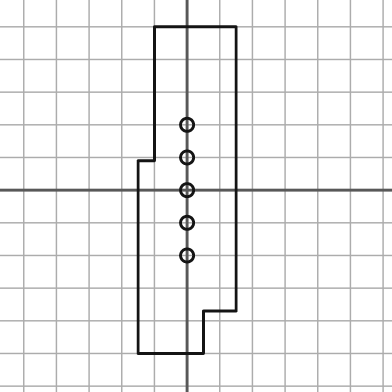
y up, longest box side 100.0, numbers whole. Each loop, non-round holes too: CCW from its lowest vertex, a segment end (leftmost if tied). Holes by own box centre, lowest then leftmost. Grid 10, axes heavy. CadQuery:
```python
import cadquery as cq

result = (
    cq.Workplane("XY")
    .moveTo(-15.0, -50.0)
    .lineTo(5.0, -50.0)
    .lineTo(5.0, -37.0)
    .lineTo(15.0, -37.0)
    .lineTo(15.0, 50.0)
    .lineTo(-10.0, 50.0)
    .lineTo(-10.0, 9.0)
    .lineTo(-15.0, 9.0)
    .close()
    .moveTo(0.0, -20.0)
    .circle(2.0)
    .moveTo(0.0, -10.0)
    .circle(2.0)
    .moveTo(0.0, 0.0)
    .circle(2.0)
    .moveTo(0.0, 10.0)
    .circle(2.0)
    .moveTo(0.0, 20.0)
    .circle(2.0)
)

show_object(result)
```